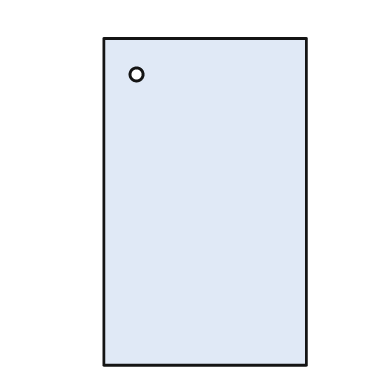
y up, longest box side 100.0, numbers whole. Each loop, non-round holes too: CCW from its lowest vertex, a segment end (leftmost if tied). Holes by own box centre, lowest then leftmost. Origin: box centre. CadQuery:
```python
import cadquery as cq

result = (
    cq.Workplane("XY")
    .moveTo(-31.0, -50.0)
    .lineTo(31.0, -50.0)
    .lineTo(31.0, 50.0)
    .lineTo(-31.0, 50.0)
    .close()
    .moveTo(-21.0, 39.0)
    .circle(2.0)
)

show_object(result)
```